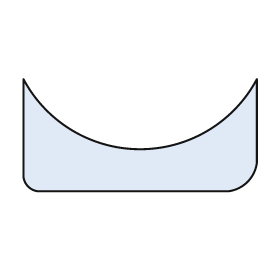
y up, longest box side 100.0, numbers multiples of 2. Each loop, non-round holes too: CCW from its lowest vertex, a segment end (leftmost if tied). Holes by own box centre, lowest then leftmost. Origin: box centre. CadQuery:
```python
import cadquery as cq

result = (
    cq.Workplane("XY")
    .moveTo(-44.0, -24.0)
    .lineTo(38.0, -24.0)
    .threePointArc((46.0, -20.0), (50.0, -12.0))
    .lineTo(50.0, 24.0)
    .threePointArc((0.0, -6.0), (-50.0, 24.0))
    .lineTo(-50.0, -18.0)
    .threePointArc((-48.0, -22.0), (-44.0, -24.0))
    .close()
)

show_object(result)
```